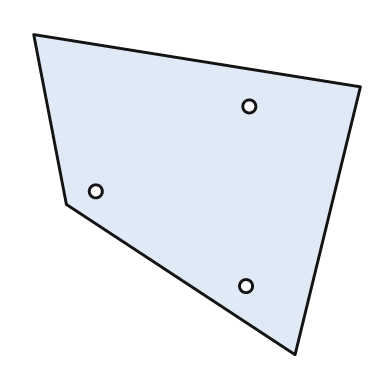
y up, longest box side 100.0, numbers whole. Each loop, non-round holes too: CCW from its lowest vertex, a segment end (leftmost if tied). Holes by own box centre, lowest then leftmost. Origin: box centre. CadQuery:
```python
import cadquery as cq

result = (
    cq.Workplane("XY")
    .moveTo(30.0, -49.0)
    .lineTo(50.0, 33.0)
    .lineTo(-50.0, 49.0)
    .lineTo(-40.0, -3.0)
    .close()
    .moveTo(15.0, -28.0)
    .circle(2.0)
    .moveTo(-31.0, 1.0)
    .circle(2.0)
    .moveTo(16.0, 27.0)
    .circle(2.0)
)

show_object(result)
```